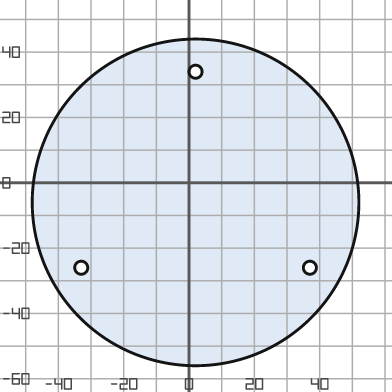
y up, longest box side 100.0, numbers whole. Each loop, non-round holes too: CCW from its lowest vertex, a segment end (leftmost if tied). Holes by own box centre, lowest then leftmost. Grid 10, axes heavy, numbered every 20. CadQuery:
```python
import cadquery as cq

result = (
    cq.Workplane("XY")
    .moveTo(2.0, -6.0)
    .circle(50.0)
    .moveTo(-33.0, -26.0)
    .circle(2.0)
    .moveTo(37.0, -26.0)
    .circle(2.0)
    .moveTo(2.0, 34.0)
    .circle(2.0)
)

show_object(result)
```